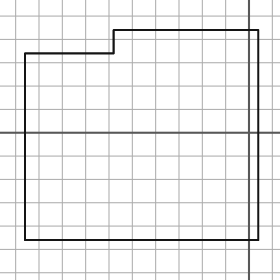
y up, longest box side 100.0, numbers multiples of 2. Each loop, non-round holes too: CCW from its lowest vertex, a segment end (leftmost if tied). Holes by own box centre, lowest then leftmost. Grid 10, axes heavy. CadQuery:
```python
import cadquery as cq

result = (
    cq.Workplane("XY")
    .moveTo(-96.0, -46.0)
    .lineTo(4.0, -46.0)
    .lineTo(4.0, 44.0)
    .lineTo(-58.0, 44.0)
    .lineTo(-58.0, 34.0)
    .lineTo(-96.0, 34.0)
    .close()
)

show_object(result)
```